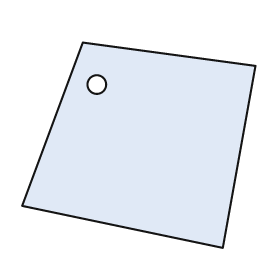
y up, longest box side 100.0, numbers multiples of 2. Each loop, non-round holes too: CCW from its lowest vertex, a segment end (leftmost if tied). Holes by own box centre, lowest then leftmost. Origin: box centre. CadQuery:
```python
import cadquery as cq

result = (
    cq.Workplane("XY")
    .moveTo(36.0, -44.0)
    .lineTo(50.0, 34.0)
    .lineTo(-24.0, 44.0)
    .lineTo(-50.0, -26.0)
    .close()
    .moveTo(-18.0, 26.0)
    .circle(4.0)
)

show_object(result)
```